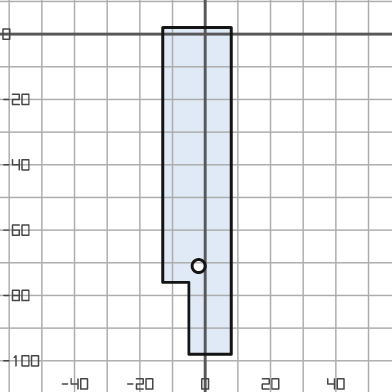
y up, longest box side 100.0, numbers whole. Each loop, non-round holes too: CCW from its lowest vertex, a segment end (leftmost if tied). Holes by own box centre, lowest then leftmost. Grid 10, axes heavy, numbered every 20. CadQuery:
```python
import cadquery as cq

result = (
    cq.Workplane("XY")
    .moveTo(-5.0, -98.0)
    .lineTo(8.0, -98.0)
    .lineTo(8.0, 2.0)
    .lineTo(-13.0, 2.0)
    .lineTo(-13.0, -76.0)
    .lineTo(-5.0, -76.0)
    .close()
    .moveTo(-2.0, -71.0)
    .circle(2.0)
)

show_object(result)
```